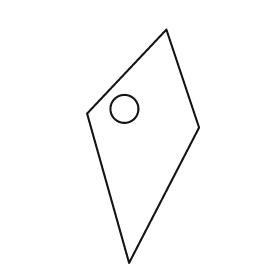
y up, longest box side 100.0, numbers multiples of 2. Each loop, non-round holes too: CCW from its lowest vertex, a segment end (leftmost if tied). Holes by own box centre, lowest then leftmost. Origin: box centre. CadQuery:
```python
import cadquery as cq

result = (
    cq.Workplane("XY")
    .moveTo(-6.0, -50.0)
    .lineTo(24.0, 8.0)
    .lineTo(10.0, 50.0)
    .lineTo(-24.0, 14.0)
    .close()
    .moveTo(-8.0, 16.0)
    .circle(6.0)
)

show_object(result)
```